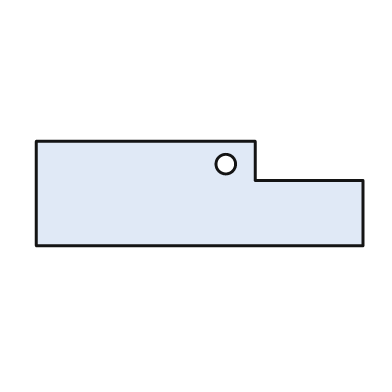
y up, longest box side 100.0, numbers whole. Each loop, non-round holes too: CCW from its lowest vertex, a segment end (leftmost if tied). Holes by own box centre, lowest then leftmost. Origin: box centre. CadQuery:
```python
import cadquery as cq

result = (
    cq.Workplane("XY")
    .moveTo(-50.0, -16.0)
    .lineTo(50.0, -16.0)
    .lineTo(50.0, 4.0)
    .lineTo(17.0, 4.0)
    .lineTo(17.0, 16.0)
    .lineTo(-50.0, 16.0)
    .close()
    .moveTo(8.0, 9.0)
    .circle(3.0)
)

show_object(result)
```